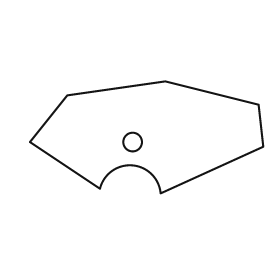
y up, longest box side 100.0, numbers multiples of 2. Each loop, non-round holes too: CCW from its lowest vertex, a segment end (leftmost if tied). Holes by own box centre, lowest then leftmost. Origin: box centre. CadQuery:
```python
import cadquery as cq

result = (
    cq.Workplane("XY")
    .moveTo(6.0, -24.0)
    .lineTo(50.0, -4.0)
    .lineTo(48.0, 14.0)
    .lineTo(8.0, 24.0)
    .lineTo(-34.0, 18.0)
    .lineTo(-50.0, -2.0)
    .lineTo(-20.0, -22.0)
    .threePointArc((-6.0, -12.0), (6.0, -24.0))
    .close()
    .moveTo(-6.0, -2.0)
    .circle(4.0)
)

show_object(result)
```